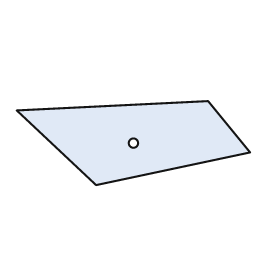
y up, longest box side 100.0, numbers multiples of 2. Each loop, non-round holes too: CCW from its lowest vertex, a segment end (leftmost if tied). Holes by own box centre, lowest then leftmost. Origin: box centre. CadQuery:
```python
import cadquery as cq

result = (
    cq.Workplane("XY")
    .moveTo(-16.0, -18.0)
    .lineTo(50.0, -4.0)
    .lineTo(32.0, 18.0)
    .lineTo(-50.0, 14.0)
    .close()
    .moveTo(0.0, 0.0)
    .circle(2.0)
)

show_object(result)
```